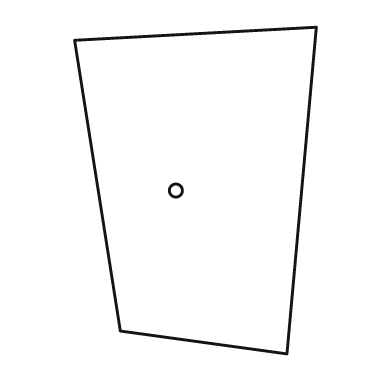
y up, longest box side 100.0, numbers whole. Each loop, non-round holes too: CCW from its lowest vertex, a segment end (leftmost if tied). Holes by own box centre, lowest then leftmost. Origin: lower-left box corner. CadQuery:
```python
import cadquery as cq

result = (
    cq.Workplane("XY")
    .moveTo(65.0, 0.0)
    .lineTo(74.0, 100.0)
    .lineTo(0.0, 96.0)
    .lineTo(14.0, 7.0)
    .close()
    .moveTo(31.0, 50.0)
    .circle(2.0)
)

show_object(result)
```